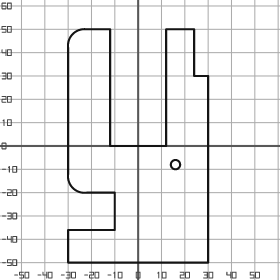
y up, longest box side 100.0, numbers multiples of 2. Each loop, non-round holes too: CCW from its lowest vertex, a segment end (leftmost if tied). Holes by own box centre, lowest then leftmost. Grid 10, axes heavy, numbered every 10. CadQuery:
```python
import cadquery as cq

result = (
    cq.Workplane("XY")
    .moveTo(-30.0, -50.0)
    .lineTo(30.0, -50.0)
    .lineTo(30.0, 30.0)
    .lineTo(24.0, 30.0)
    .lineTo(24.0, 50.0)
    .lineTo(12.0, 50.0)
    .lineTo(12.0, 0.0)
    .lineTo(-12.0, 0.0)
    .lineTo(-12.0, 50.0)
    .lineTo(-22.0, 50.0)
    .threePointArc((-28.0, 48.0), (-30.0, 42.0))
    .lineTo(-30.0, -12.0)
    .threePointArc((-28.0, -18.0), (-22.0, -20.0))
    .lineTo(-10.0, -20.0)
    .lineTo(-10.0, -36.0)
    .lineTo(-30.0, -36.0)
    .close()
    .moveTo(16.0, -8.0)
    .circle(2.0)
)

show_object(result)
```